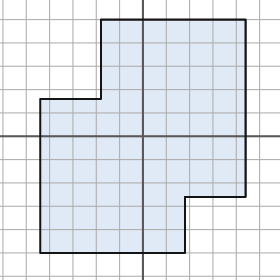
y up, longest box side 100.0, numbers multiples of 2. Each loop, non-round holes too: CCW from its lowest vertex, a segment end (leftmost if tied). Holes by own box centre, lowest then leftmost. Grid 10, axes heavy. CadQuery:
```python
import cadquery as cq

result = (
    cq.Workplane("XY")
    .moveTo(-44.0, -50.0)
    .lineTo(18.0, -50.0)
    .lineTo(18.0, -26.0)
    .lineTo(44.0, -26.0)
    .lineTo(44.0, 50.0)
    .lineTo(-18.0, 50.0)
    .lineTo(-18.0, 16.0)
    .lineTo(-44.0, 16.0)
    .close()
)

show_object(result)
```